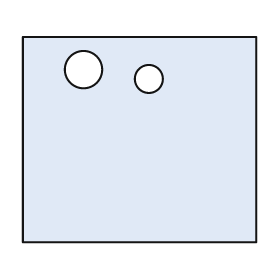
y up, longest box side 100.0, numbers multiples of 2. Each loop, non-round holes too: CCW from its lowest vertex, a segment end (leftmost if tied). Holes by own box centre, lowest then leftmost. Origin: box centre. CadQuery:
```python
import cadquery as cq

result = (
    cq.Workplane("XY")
    .moveTo(-50.0, -44.0)
    .lineTo(50.0, -44.0)
    .lineTo(50.0, 44.0)
    .lineTo(-50.0, 44.0)
    .close()
    .moveTo(4.0, 26.0)
    .circle(6.0)
    .moveTo(-24.0, 30.0)
    .circle(8.0)
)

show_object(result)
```